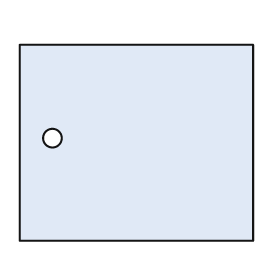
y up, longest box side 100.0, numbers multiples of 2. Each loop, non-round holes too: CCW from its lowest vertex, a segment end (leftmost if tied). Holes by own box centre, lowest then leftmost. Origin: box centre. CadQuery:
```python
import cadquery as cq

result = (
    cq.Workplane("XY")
    .moveTo(-50.0, -42.0)
    .lineTo(50.0, -42.0)
    .lineTo(50.0, 42.0)
    .lineTo(-50.0, 42.0)
    .close()
    .moveTo(-36.0, 2.0)
    .circle(4.0)
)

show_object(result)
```